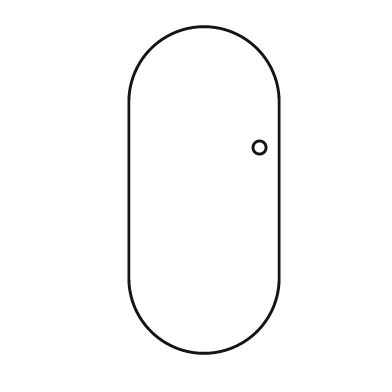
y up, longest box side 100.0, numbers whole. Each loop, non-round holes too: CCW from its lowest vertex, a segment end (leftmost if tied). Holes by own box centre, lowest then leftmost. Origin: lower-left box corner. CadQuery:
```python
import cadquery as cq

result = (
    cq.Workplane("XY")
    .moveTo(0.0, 23.0)
    .threePointArc((23.0, 0.0), (46.0, 23.0))
    .lineTo(46.0, 77.0)
    .threePointArc((23.0, 100.0), (0.0, 77.0))
    .close()
    .moveTo(40.0, 63.0)
    .circle(2.0)
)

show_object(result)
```